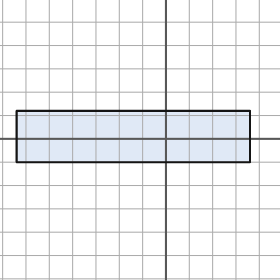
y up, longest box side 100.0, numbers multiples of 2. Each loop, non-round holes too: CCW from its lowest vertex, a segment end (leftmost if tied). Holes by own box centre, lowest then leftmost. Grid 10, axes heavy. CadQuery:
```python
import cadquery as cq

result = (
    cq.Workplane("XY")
    .moveTo(-64.0, -10.0)
    .lineTo(36.0, -10.0)
    .lineTo(36.0, 12.0)
    .lineTo(-64.0, 12.0)
    .close()
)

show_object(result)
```